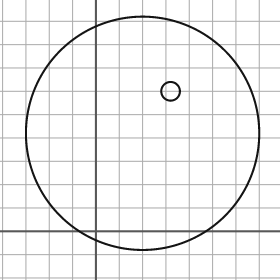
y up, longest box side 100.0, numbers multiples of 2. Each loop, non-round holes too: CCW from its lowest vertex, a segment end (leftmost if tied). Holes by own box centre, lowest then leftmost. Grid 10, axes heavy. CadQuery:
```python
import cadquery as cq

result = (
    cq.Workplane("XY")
    .moveTo(20.0, 42.0)
    .circle(50.0)
    .moveTo(32.0, 60.0)
    .circle(4.0)
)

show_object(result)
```